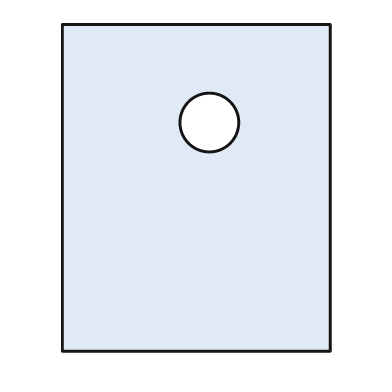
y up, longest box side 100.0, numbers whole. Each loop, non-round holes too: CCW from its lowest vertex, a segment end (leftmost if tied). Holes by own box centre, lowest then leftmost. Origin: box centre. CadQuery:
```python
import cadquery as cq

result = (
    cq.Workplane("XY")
    .moveTo(-41.0, -50.0)
    .lineTo(41.0, -50.0)
    .lineTo(41.0, 50.0)
    .lineTo(-41.0, 50.0)
    .close()
    .moveTo(4.0, 20.0)
    .circle(9.0)
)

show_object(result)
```